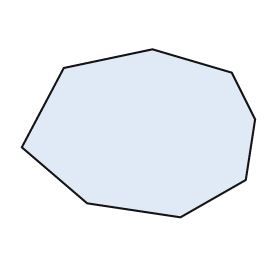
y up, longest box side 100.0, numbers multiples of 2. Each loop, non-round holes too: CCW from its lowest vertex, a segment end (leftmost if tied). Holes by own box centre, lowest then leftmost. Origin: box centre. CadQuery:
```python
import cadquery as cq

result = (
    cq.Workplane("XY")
    .moveTo(18.0, -36.0)
    .lineTo(46.0, -20.0)
    .lineTo(50.0, 6.0)
    .lineTo(40.0, 26.0)
    .lineTo(6.0, 36.0)
    .lineTo(-32.0, 28.0)
    .lineTo(-50.0, -6.0)
    .lineTo(-22.0, -30.0)
    .close()
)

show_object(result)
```